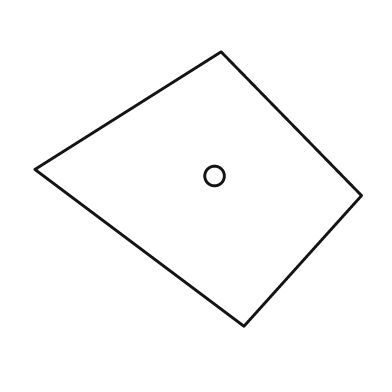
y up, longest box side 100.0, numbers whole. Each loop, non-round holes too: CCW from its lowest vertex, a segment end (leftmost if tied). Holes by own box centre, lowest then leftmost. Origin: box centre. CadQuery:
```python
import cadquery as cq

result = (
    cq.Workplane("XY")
    .moveTo(14.0, -42.0)
    .lineTo(50.0, -2.0)
    .lineTo(7.0, 42.0)
    .lineTo(-50.0, 6.0)
    .close()
    .moveTo(5.0, 4.0)
    .circle(3.0)
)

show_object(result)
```